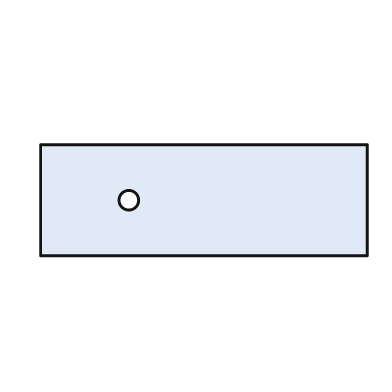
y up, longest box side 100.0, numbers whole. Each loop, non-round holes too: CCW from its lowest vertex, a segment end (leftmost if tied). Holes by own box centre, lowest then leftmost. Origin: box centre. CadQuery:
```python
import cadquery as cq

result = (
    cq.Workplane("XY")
    .moveTo(-50.0, -17.0)
    .lineTo(50.0, -17.0)
    .lineTo(50.0, 17.0)
    .lineTo(-50.0, 17.0)
    .close()
    .moveTo(-23.0, 0.0)
    .circle(3.0)
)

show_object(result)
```